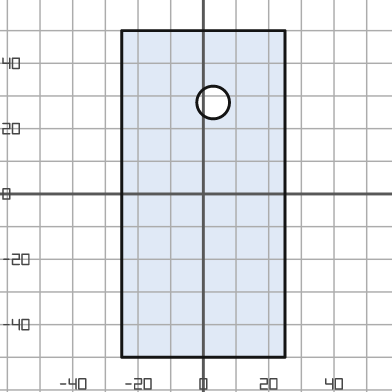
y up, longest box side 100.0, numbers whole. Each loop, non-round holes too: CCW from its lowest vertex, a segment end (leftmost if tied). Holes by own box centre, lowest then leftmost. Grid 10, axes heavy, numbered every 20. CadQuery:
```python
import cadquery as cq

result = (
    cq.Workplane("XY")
    .moveTo(-25.0, -50.0)
    .lineTo(25.0, -50.0)
    .lineTo(25.0, 50.0)
    .lineTo(-25.0, 50.0)
    .close()
    .moveTo(3.0, 28.0)
    .circle(5.0)
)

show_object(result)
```